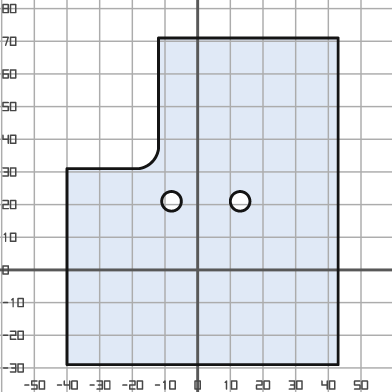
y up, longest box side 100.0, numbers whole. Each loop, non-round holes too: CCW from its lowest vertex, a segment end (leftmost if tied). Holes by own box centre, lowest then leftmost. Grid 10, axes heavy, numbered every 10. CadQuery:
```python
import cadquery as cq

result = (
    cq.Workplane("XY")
    .moveTo(-40.0, -29.0)
    .lineTo(43.0, -29.0)
    .lineTo(43.0, 71.0)
    .lineTo(-12.0, 71.0)
    .lineTo(-12.0, 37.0)
    .threePointArc((-14.0, 33.0), (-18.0, 31.0))
    .lineTo(-40.0, 31.0)
    .close()
    .moveTo(-8.0, 21.0)
    .circle(3.0)
    .moveTo(13.0, 21.0)
    .circle(3.0)
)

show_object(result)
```